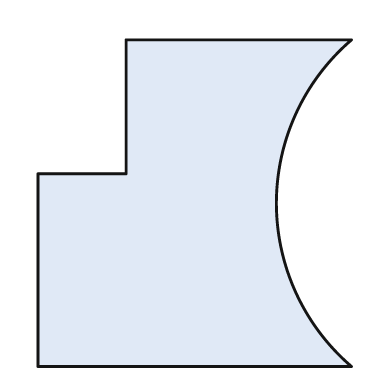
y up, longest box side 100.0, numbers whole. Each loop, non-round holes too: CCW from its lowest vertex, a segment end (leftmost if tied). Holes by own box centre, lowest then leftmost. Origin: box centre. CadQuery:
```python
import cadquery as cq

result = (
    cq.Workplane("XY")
    .moveTo(-48.0, -50.0)
    .lineTo(48.0, -50.0)
    .threePointArc((25.0, 0.0), (48.0, 50.0))
    .lineTo(-21.0, 50.0)
    .lineTo(-21.0, 9.0)
    .lineTo(-48.0, 9.0)
    .close()
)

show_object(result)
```